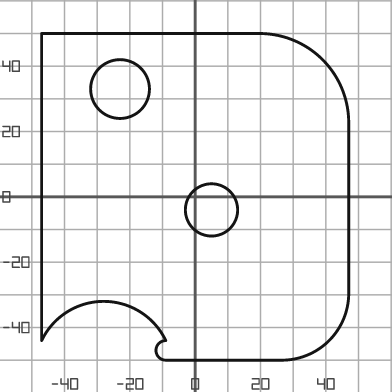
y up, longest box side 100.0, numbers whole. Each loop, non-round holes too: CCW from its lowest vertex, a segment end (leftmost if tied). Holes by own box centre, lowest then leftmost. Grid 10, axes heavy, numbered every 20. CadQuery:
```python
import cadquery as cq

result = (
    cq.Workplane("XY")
    .moveTo(-9.0, -50.0)
    .lineTo(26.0, -50.0)
    .threePointArc((41.0, -44.0), (47.0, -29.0))
    .lineTo(47.0, 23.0)
    .threePointArc((39.0, 42.0), (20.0, 50.0))
    .lineTo(-47.0, 50.0)
    .lineTo(-47.0, -44.0)
    .threePointArc((-28.0, -32.0), (-9.0, -44.0))
    .threePointArc((-12.0, -47.0), (-9.0, -50.0))
    .close()
    .moveTo(5.0, -4.0)
    .circle(8.0)
    .moveTo(-23.0, 33.0)
    .circle(9.0)
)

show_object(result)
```